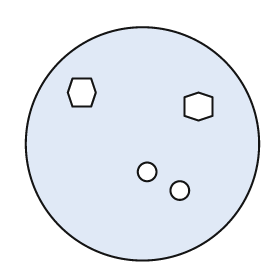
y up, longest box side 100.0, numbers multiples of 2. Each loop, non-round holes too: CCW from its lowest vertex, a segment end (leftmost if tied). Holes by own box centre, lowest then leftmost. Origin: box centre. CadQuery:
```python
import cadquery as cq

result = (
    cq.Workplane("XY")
    .moveTo(0.0, 0.0)
    .circle(50.0)
    .moveTo(16.0, -20.0)
    .circle(4.0)
    .moveTo(2.0, -12.0)
    .circle(4.0)
    .moveTo(24.0, 10.0)
    .lineTo(30.0, 12.0)
    .lineTo(30.0, 20.0)
    .lineTo(24.0, 22.0)
    .lineTo(18.0, 20.0)
    .lineTo(18.0, 12.0)
    .close()
    .moveTo(-30.0, 16.0)
    .lineTo(-22.0, 16.0)
    .lineTo(-20.0, 22.0)
    .lineTo(-22.0, 28.0)
    .lineTo(-30.0, 28.0)
    .lineTo(-32.0, 22.0)
    .close()
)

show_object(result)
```